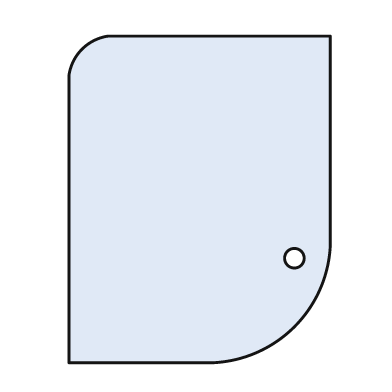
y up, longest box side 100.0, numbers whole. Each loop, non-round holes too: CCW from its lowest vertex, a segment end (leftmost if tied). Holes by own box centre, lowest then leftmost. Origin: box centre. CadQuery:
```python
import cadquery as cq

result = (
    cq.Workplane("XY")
    .moveTo(-40.0, -50.0)
    .lineTo(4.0, -50.0)
    .threePointArc((29.0, -39.0), (40.0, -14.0))
    .lineTo(40.0, 50.0)
    .lineTo(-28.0, 50.0)
    .threePointArc((-36.0, 46.0), (-40.0, 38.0))
    .close()
    .moveTo(29.0, -18.0)
    .circle(3.0)
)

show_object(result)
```